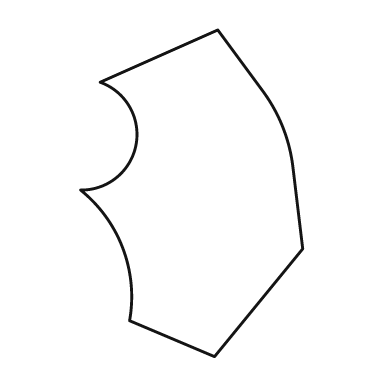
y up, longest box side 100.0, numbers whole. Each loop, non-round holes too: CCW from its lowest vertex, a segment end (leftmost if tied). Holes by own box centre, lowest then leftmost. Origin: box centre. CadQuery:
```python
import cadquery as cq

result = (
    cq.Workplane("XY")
    .moveTo(7.0, -50.0)
    .lineTo(34.0, -17.0)
    .lineTo(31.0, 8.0)
    .threePointArc((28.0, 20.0), (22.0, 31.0))
    .lineTo(8.0, 50.0)
    .lineTo(-28.0, 34.0)
    .threePointArc((-17.0, 15.0), (-34.0, 1.0))
    .threePointArc((-21.0, -17.0), (-19.0, -39.0))
    .close()
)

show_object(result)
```